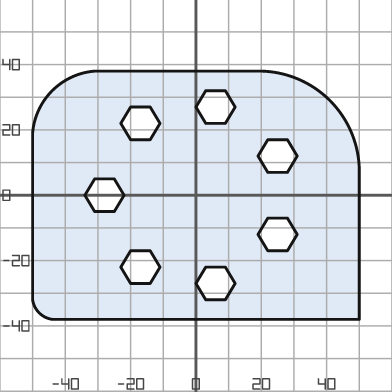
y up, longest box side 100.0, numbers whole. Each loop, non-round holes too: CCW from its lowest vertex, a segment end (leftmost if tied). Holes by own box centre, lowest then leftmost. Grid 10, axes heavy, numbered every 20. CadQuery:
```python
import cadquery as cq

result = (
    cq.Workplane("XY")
    .moveTo(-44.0, -38.0)
    .lineTo(50.0, -38.0)
    .lineTo(50.0, 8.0)
    .threePointArc((41.0, 29.0), (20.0, 38.0))
    .lineTo(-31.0, 38.0)
    .threePointArc((-44.0, 32.0), (-50.0, 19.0))
    .lineTo(-50.0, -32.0)
    .threePointArc((-48.0, -36.0), (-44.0, -38.0))
    .close()
    .moveTo(3.0, -32.0)
    .lineTo(9.0, -32.0)
    .lineTo(12.0, -27.0)
    .lineTo(9.0, -22.0)
    .lineTo(3.0, -22.0)
    .lineTo(0.0, -27.0)
    .close()
    .moveTo(-20.0, -27.0)
    .lineTo(-14.0, -27.0)
    .lineTo(-11.0, -22.0)
    .lineTo(-14.0, -17.0)
    .lineTo(-20.0, -17.0)
    .lineTo(-23.0, -22.0)
    .close()
    .moveTo(22.0, -17.0)
    .lineTo(28.0, -17.0)
    .lineTo(31.0, -12.0)
    .lineTo(28.0, -7.0)
    .lineTo(22.0, -7.0)
    .lineTo(19.0, -12.0)
    .close()
    .moveTo(-31.0, -5.0)
    .lineTo(-25.0, -5.0)
    .lineTo(-22.0, 0.0)
    .lineTo(-25.0, 5.0)
    .lineTo(-31.0, 5.0)
    .lineTo(-34.0, 0.0)
    .close()
    .moveTo(22.0, 7.0)
    .lineTo(28.0, 7.0)
    .lineTo(31.0, 12.0)
    .lineTo(28.0, 17.0)
    .lineTo(22.0, 17.0)
    .lineTo(19.0, 12.0)
    .close()
    .moveTo(-20.0, 17.0)
    .lineTo(-14.0, 17.0)
    .lineTo(-11.0, 22.0)
    .lineTo(-14.0, 27.0)
    .lineTo(-20.0, 27.0)
    .lineTo(-23.0, 22.0)
    .close()
    .moveTo(3.0, 22.0)
    .lineTo(9.0, 22.0)
    .lineTo(12.0, 27.0)
    .lineTo(9.0, 32.0)
    .lineTo(3.0, 32.0)
    .lineTo(0.0, 27.0)
    .close()
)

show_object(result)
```